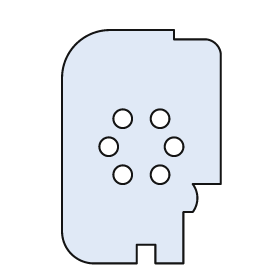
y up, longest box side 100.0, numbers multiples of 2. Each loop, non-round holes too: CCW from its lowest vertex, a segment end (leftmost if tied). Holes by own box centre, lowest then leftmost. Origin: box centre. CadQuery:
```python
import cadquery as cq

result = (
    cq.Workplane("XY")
    .moveTo(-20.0, -50.0)
    .lineTo(-2.0, -50.0)
    .lineTo(-2.0, -42.0)
    .lineTo(6.0, -42.0)
    .lineTo(6.0, -50.0)
    .lineTo(18.0, -50.0)
    .lineTo(18.0, -28.0)
    .lineTo(22.0, -28.0)
    .threePointArc((24.0, -22.0), (22.0, -16.0))
    .lineTo(34.0, -16.0)
    .lineTo(34.0, 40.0)
    .threePointArc((32.0, 44.0), (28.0, 46.0))
    .lineTo(14.0, 46.0)
    .lineTo(14.0, 50.0)
    .lineTo(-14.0, 50.0)
    .threePointArc((-28.0, 44.0), (-34.0, 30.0))
    .lineTo(-34.0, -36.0)
    .threePointArc((-30.0, -46.0), (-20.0, -50.0))
    .close()
    .moveTo(-8.0, -12.0)
    .circle(4.0)
    .moveTo(8.0, -12.0)
    .circle(4.0)
    .moveTo(-14.0, 0.0)
    .circle(4.0)
    .moveTo(14.0, 0.0)
    .circle(4.0)
    .moveTo(-8.0, 12.0)
    .circle(4.0)
    .moveTo(8.0, 12.0)
    .circle(4.0)
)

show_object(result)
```